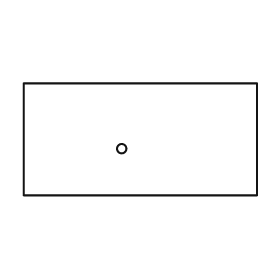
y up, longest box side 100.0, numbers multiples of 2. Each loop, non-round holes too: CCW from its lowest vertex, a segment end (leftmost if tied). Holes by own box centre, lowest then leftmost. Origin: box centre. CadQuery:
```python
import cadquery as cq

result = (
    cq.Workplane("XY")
    .moveTo(-50.0, -24.0)
    .lineTo(50.0, -24.0)
    .lineTo(50.0, 24.0)
    .lineTo(-50.0, 24.0)
    .close()
    .moveTo(-8.0, -4.0)
    .circle(2.0)
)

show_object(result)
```